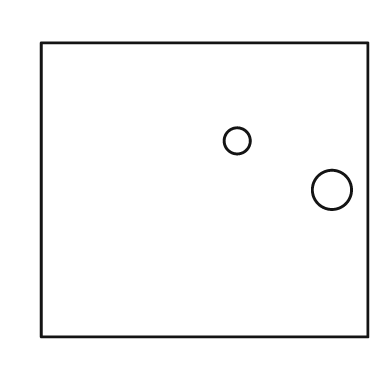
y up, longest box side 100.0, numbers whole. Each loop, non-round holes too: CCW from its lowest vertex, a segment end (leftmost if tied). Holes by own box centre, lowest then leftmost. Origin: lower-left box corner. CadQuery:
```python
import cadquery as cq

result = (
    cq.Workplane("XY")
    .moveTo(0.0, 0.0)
    .lineTo(100.0, 0.0)
    .lineTo(100.0, 90.0)
    .lineTo(0.0, 90.0)
    .close()
    .moveTo(89.0, 45.0)
    .circle(6.0)
    .moveTo(60.0, 60.0)
    .circle(4.0)
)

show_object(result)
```